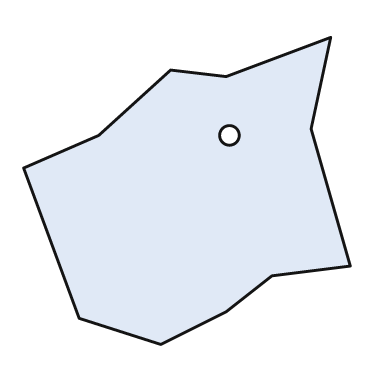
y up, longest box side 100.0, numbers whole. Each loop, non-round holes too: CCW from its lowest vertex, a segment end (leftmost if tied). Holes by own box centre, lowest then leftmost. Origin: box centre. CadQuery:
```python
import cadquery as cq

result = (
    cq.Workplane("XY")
    .moveTo(-8.0, -47.0)
    .lineTo(12.0, -37.0)
    .lineTo(26.0, -26.0)
    .lineTo(50.0, -23.0)
    .lineTo(38.0, 19.0)
    .lineTo(44.0, 47.0)
    .lineTo(12.0, 35.0)
    .lineTo(-5.0, 37.0)
    .lineTo(-27.0, 17.0)
    .lineTo(-50.0, 7.0)
    .lineTo(-33.0, -39.0)
    .close()
    .moveTo(13.0, 17.0)
    .circle(3.0)
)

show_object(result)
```